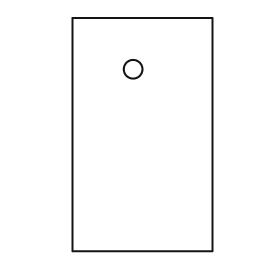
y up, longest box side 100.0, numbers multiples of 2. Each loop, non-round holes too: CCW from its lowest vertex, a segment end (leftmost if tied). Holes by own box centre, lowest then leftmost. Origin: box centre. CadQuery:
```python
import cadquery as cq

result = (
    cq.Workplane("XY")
    .moveTo(-30.0, -50.0)
    .lineTo(30.0, -50.0)
    .lineTo(30.0, 50.0)
    .lineTo(-30.0, 50.0)
    .close()
    .moveTo(-4.0, 28.0)
    .circle(4.0)
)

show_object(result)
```